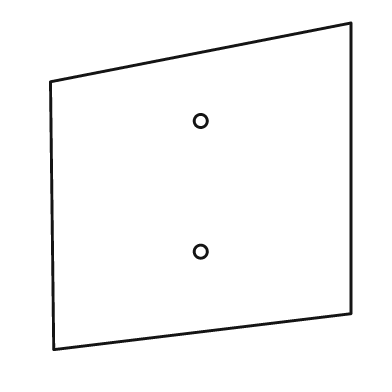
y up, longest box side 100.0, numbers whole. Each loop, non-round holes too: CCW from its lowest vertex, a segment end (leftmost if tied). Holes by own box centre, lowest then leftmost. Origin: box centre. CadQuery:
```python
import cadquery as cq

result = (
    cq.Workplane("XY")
    .moveTo(-45.0, -50.0)
    .lineTo(46.0, -39.0)
    .lineTo(46.0, 50.0)
    .lineTo(-46.0, 32.0)
    .close()
    .moveTo(0.0, -20.0)
    .circle(2.0)
    .moveTo(0.0, 20.0)
    .circle(2.0)
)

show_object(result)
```